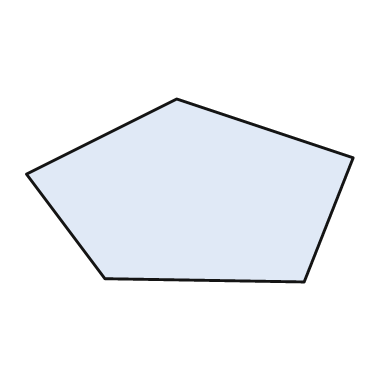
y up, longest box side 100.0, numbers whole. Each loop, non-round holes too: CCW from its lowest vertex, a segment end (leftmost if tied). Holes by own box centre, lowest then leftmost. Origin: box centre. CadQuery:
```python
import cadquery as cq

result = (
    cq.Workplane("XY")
    .moveTo(35.0, -28.0)
    .lineTo(50.0, 10.0)
    .lineTo(-4.0, 28.0)
    .lineTo(-50.0, 5.0)
    .lineTo(-26.0, -27.0)
    .close()
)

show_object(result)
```